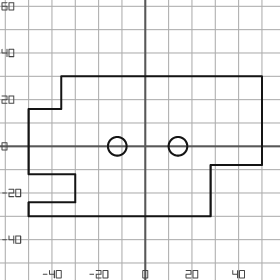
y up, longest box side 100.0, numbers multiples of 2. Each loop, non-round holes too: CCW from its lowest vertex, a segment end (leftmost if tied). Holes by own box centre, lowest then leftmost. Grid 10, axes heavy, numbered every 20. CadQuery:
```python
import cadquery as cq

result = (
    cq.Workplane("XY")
    .moveTo(-50.0, -30.0)
    .lineTo(28.0, -30.0)
    .lineTo(28.0, -8.0)
    .lineTo(50.0, -8.0)
    .lineTo(50.0, 30.0)
    .lineTo(-36.0, 30.0)
    .lineTo(-36.0, 16.0)
    .lineTo(-50.0, 16.0)
    .lineTo(-50.0, -12.0)
    .lineTo(-30.0, -12.0)
    .lineTo(-30.0, -24.0)
    .lineTo(-50.0, -24.0)
    .close()
    .moveTo(-12.0, 0.0)
    .circle(4.0)
    .moveTo(14.0, 0.0)
    .circle(4.0)
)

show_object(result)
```